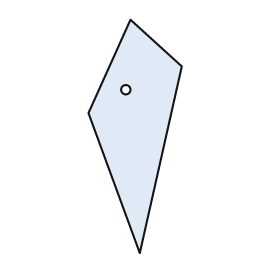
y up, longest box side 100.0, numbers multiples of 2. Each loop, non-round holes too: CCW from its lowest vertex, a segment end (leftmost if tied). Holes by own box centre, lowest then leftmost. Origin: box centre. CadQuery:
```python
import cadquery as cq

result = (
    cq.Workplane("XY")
    .moveTo(2.0, -50.0)
    .lineTo(20.0, 30.0)
    .lineTo(-2.0, 50.0)
    .lineTo(-20.0, 10.0)
    .close()
    .moveTo(-4.0, 20.0)
    .circle(2.0)
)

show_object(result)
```